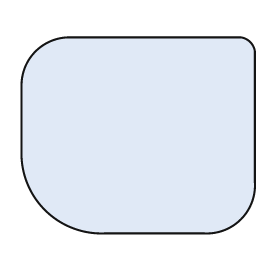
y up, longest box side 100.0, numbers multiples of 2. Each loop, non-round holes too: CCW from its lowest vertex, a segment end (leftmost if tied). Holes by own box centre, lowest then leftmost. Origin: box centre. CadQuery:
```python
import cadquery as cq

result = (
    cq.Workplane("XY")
    .moveTo(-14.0, -42.0)
    .lineTo(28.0, -42.0)
    .threePointArc((44.0, -36.0), (50.0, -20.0))
    .lineTo(50.0, 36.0)
    .threePointArc((48.0, 40.0), (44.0, 42.0))
    .lineTo(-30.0, 42.0)
    .threePointArc((-44.0, 36.0), (-50.0, 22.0))
    .lineTo(-50.0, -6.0)
    .threePointArc((-40.0, -32.0), (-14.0, -42.0))
    .close()
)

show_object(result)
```